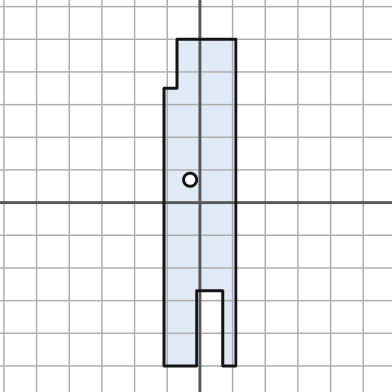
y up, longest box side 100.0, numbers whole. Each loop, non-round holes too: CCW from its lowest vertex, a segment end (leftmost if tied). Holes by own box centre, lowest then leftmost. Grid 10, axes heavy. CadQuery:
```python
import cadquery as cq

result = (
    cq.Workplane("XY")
    .moveTo(-11.0, -50.0)
    .lineTo(-1.0, -50.0)
    .lineTo(-1.0, -27.0)
    .lineTo(7.0, -27.0)
    .lineTo(7.0, -50.0)
    .lineTo(11.0, -50.0)
    .lineTo(11.0, 50.0)
    .lineTo(-7.0, 50.0)
    .lineTo(-7.0, 35.0)
    .lineTo(-11.0, 35.0)
    .close()
    .moveTo(-3.0, 7.0)
    .circle(2.0)
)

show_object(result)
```